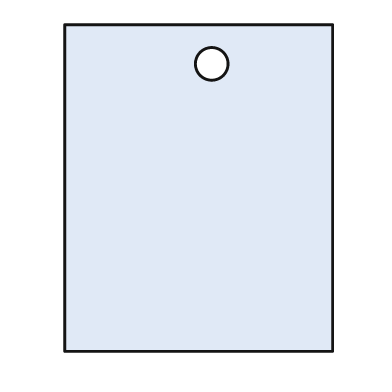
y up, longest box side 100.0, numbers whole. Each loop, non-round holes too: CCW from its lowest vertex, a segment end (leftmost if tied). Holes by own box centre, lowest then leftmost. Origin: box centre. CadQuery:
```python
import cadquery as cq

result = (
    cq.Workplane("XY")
    .moveTo(-41.0, -50.0)
    .lineTo(41.0, -50.0)
    .lineTo(41.0, 50.0)
    .lineTo(-41.0, 50.0)
    .close()
    .moveTo(4.0, 38.0)
    .circle(5.0)
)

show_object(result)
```